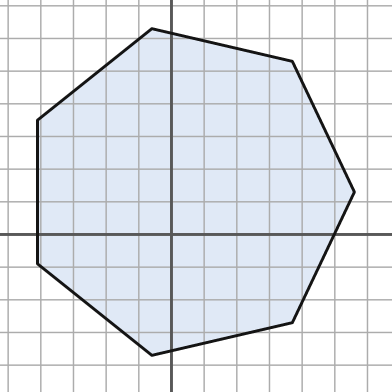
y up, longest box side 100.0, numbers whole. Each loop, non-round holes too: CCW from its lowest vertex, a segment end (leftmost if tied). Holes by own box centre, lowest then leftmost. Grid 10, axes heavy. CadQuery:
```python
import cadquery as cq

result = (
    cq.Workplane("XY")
    .moveTo(-6.0, -37.0)
    .lineTo(37.0, -27.0)
    .lineTo(56.0, 13.0)
    .lineTo(37.0, 53.0)
    .lineTo(-6.0, 63.0)
    .lineTo(-41.0, 35.0)
    .lineTo(-41.0, -9.0)
    .close()
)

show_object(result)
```